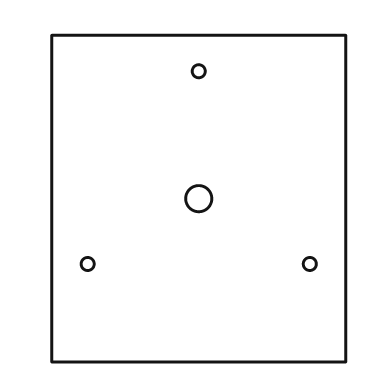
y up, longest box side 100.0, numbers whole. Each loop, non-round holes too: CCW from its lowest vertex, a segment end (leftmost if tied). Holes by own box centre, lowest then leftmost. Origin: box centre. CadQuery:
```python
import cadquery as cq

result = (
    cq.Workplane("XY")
    .moveTo(-45.0, -50.0)
    .lineTo(45.0, -50.0)
    .lineTo(45.0, 50.0)
    .lineTo(-45.0, 50.0)
    .close()
    .moveTo(-34.0, -20.0)
    .circle(2.0)
    .moveTo(34.0, -20.0)
    .circle(2.0)
    .moveTo(0.0, 0.0)
    .circle(4.0)
    .moveTo(0.0, 39.0)
    .circle(2.0)
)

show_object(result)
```